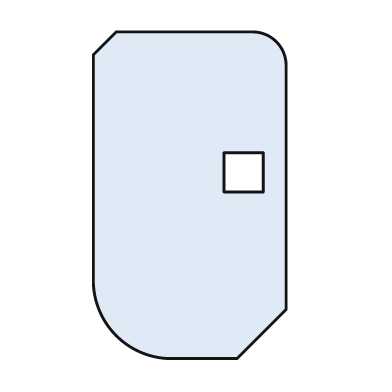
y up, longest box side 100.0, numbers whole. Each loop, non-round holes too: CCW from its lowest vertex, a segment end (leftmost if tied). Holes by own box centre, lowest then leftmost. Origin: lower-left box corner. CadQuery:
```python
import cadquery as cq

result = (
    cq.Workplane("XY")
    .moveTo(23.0, 0.0)
    .lineTo(44.0, 0.0)
    .lineTo(59.0, 15.0)
    .lineTo(59.0, 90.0)
    .threePointArc((56.0, 97.0), (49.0, 100.0))
    .lineTo(7.0, 100.0)
    .lineTo(0.0, 93.0)
    .lineTo(0.0, 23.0)
    .threePointArc((7.0, 7.0), (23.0, 0.0))
    .close()
    .moveTo(40.0, 51.0)
    .lineTo(52.0, 51.0)
    .lineTo(52.0, 63.0)
    .lineTo(40.0, 63.0)
    .close()
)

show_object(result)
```